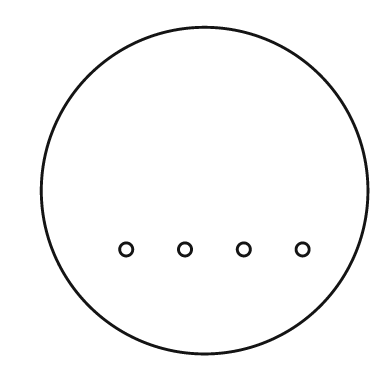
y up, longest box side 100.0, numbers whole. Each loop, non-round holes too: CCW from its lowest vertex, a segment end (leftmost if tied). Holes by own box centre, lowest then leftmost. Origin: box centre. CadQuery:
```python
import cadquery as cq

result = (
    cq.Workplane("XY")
    .moveTo(0.0, 0.0)
    .circle(50.0)
    .moveTo(-24.0, -18.0)
    .circle(2.0)
    .moveTo(-6.0, -18.0)
    .circle(2.0)
    .moveTo(12.0, -18.0)
    .circle(2.0)
    .moveTo(30.0, -18.0)
    .circle(2.0)
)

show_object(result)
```